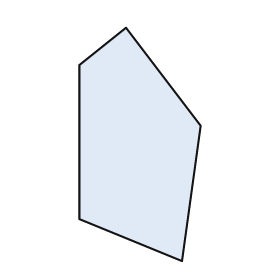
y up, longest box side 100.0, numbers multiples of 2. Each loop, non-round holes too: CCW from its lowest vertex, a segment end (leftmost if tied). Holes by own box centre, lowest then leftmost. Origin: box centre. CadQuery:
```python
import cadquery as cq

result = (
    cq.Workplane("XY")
    .moveTo(18.0, -50.0)
    .lineTo(26.0, 8.0)
    .lineTo(-6.0, 50.0)
    .lineTo(-26.0, 34.0)
    .lineTo(-26.0, -32.0)
    .close()
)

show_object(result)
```